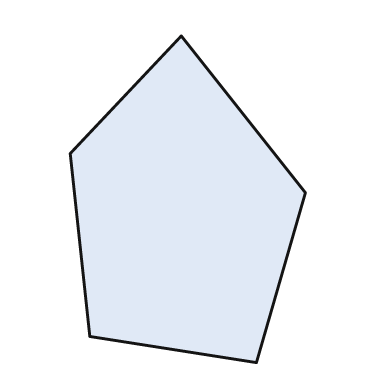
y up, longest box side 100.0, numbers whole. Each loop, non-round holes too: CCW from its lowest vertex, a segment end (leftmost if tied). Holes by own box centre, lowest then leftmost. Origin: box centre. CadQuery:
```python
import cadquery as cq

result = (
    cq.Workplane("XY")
    .moveTo(21.0, -50.0)
    .lineTo(36.0, 2.0)
    .lineTo(-2.0, 50.0)
    .lineTo(-36.0, 14.0)
    .lineTo(-30.0, -42.0)
    .close()
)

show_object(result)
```